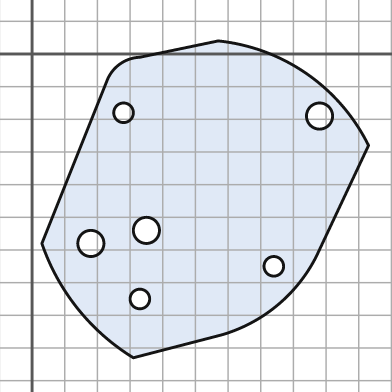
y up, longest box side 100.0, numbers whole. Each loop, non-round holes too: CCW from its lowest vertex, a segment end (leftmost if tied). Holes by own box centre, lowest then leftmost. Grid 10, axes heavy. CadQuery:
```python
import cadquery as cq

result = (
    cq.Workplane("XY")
    .moveTo(31.0, -93.0)
    .lineTo(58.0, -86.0)
    .threePointArc((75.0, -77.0), (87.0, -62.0))
    .lineTo(103.0, -28.0)
    .threePointArc((84.0, -6.0), (57.0, 4.0))
    .lineTo(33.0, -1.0)
    .threePointArc((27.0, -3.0), (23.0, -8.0))
    .lineTo(3.0, -58.0)
    .threePointArc((14.0, -78.0), (31.0, -93.0))
    .close()
    .moveTo(33.0, -75.0)
    .circle(3.0)
    .moveTo(74.0, -65.0)
    .circle(3.0)
    .moveTo(18.0, -58.0)
    .circle(4.0)
    .moveTo(35.0, -54.0)
    .circle(4.0)
    .moveTo(88.0, -19.0)
    .circle(4.0)
    .moveTo(28.0, -18.0)
    .circle(3.0)
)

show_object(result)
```